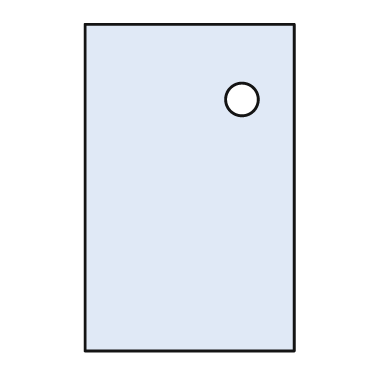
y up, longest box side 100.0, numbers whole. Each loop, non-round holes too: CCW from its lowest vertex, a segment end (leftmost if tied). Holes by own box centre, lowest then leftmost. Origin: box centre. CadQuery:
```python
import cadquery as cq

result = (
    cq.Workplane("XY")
    .moveTo(-32.0, -50.0)
    .lineTo(32.0, -50.0)
    .lineTo(32.0, 50.0)
    .lineTo(-32.0, 50.0)
    .close()
    .moveTo(16.0, 27.0)
    .circle(5.0)
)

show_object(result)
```